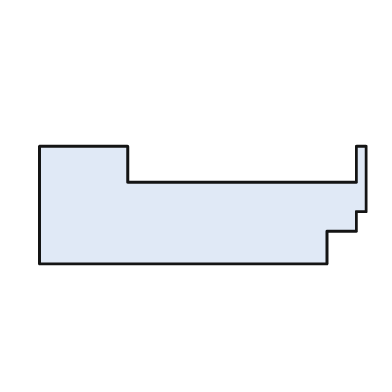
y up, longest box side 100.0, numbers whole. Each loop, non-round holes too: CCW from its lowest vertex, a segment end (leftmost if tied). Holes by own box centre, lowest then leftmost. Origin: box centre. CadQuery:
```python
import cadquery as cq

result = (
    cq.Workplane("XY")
    .moveTo(-50.0, -18.0)
    .lineTo(38.0, -18.0)
    .lineTo(38.0, -8.0)
    .lineTo(47.0, -8.0)
    .lineTo(47.0, -2.0)
    .lineTo(50.0, -2.0)
    .lineTo(50.0, 18.0)
    .lineTo(47.0, 18.0)
    .lineTo(47.0, 7.0)
    .lineTo(-23.0, 7.0)
    .lineTo(-23.0, 18.0)
    .lineTo(-50.0, 18.0)
    .close()
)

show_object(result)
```